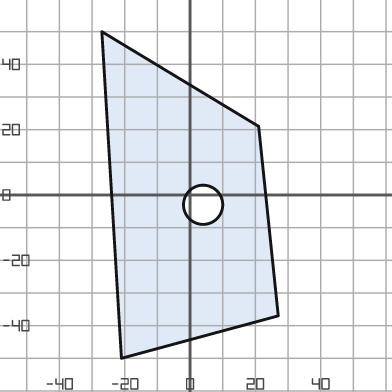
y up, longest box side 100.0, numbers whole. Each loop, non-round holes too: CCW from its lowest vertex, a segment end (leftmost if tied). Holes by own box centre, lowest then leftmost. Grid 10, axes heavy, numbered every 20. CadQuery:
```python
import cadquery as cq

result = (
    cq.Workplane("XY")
    .moveTo(-21.0, -50.0)
    .lineTo(27.0, -37.0)
    .lineTo(21.0, 21.0)
    .lineTo(-27.0, 50.0)
    .close()
    .moveTo(4.0, -3.0)
    .circle(6.0)
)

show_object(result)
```